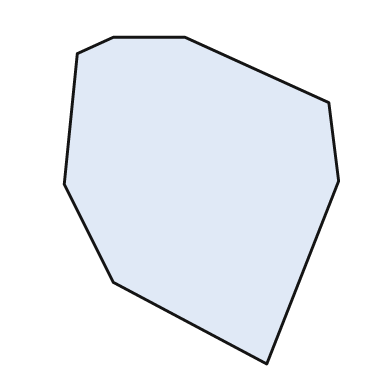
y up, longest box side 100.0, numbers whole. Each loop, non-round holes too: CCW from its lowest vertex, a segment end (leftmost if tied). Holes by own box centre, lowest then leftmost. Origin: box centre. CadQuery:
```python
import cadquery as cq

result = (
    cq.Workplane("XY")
    .moveTo(20.0, -50.0)
    .lineTo(42.0, 6.0)
    .lineTo(39.0, 30.0)
    .lineTo(-5.0, 50.0)
    .lineTo(-27.0, 50.0)
    .lineTo(-38.0, 45.0)
    .lineTo(-42.0, 5.0)
    .lineTo(-27.0, -25.0)
    .close()
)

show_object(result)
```